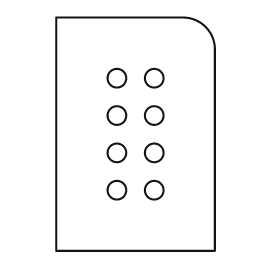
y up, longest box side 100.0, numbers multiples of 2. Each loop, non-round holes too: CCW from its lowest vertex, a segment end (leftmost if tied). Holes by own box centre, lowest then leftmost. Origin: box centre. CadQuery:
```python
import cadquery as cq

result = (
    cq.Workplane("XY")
    .moveTo(-34.0, -50.0)
    .lineTo(34.0, -50.0)
    .lineTo(34.0, 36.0)
    .threePointArc((30.0, 46.0), (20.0, 50.0))
    .lineTo(-34.0, 50.0)
    .close()
    .moveTo(-8.0, -24.0)
    .circle(4.0)
    .moveTo(8.0, -24.0)
    .circle(4.0)
    .moveTo(-8.0, -8.0)
    .circle(4.0)
    .moveTo(8.0, -8.0)
    .circle(4.0)
    .moveTo(-8.0, 8.0)
    .circle(4.0)
    .moveTo(8.0, 8.0)
    .circle(4.0)
    .moveTo(-8.0, 24.0)
    .circle(4.0)
    .moveTo(8.0, 24.0)
    .circle(4.0)
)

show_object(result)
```